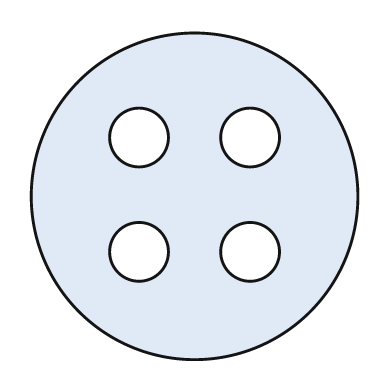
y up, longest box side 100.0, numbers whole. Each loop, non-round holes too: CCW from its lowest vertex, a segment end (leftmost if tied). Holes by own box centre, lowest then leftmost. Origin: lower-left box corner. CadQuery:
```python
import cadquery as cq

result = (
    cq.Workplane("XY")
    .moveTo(50.0, 50.0)
    .circle(50.0)
    .moveTo(33.0, 33.0)
    .circle(9.0)
    .moveTo(67.0, 33.0)
    .circle(9.0)
    .moveTo(33.0, 68.0)
    .circle(9.0)
    .moveTo(67.0, 68.0)
    .circle(9.0)
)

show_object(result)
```